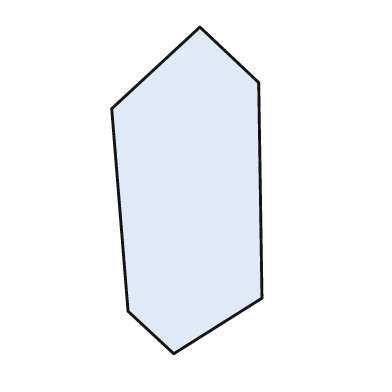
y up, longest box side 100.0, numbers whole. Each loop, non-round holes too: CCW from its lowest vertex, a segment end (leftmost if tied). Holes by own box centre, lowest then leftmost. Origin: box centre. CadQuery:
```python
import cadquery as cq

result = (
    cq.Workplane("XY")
    .moveTo(-4.0, -50.0)
    .lineTo(23.0, -33.0)
    .lineTo(22.0, 33.0)
    .lineTo(4.0, 50.0)
    .lineTo(-23.0, 25.0)
    .lineTo(-18.0, -37.0)
    .close()
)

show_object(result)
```